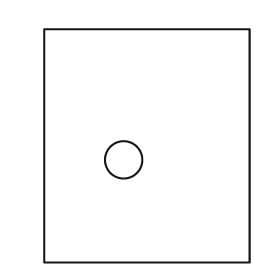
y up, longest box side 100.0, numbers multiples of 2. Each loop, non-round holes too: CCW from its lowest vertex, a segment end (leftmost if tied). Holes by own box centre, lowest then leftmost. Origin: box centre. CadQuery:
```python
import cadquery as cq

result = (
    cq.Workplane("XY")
    .moveTo(-44.0, -50.0)
    .lineTo(44.0, -50.0)
    .lineTo(44.0, 50.0)
    .lineTo(-44.0, 50.0)
    .close()
    .moveTo(-10.0, -6.0)
    .circle(8.0)
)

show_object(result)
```